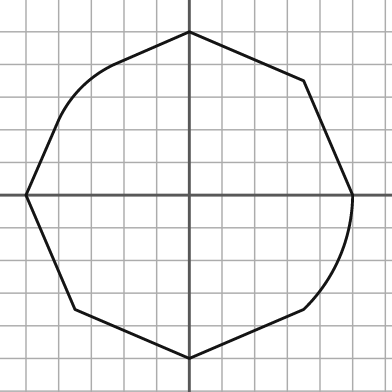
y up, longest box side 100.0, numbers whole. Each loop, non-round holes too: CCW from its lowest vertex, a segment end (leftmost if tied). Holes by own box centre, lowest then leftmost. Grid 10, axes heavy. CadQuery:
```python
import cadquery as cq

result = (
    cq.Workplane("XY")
    .moveTo(0.0, -50.0)
    .lineTo(35.0, -35.0)
    .threePointArc((46.0, -19.0), (50.0, 0.0))
    .lineTo(35.0, 35.0)
    .lineTo(0.0, 50.0)
    .lineTo(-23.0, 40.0)
    .threePointArc((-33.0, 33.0), (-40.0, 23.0))
    .lineTo(-50.0, 0.0)
    .lineTo(-35.0, -35.0)
    .close()
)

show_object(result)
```